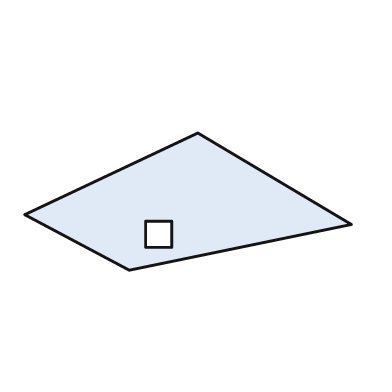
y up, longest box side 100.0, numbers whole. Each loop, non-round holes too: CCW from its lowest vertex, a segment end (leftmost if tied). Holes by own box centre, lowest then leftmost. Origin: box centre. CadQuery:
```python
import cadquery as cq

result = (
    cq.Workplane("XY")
    .moveTo(-18.0, -21.0)
    .lineTo(50.0, -7.0)
    .lineTo(3.0, 21.0)
    .lineTo(-50.0, -4.0)
    .close()
    .moveTo(-13.0, -14.0)
    .lineTo(-5.0, -14.0)
    .lineTo(-5.0, -6.0)
    .lineTo(-13.0, -6.0)
    .close()
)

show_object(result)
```